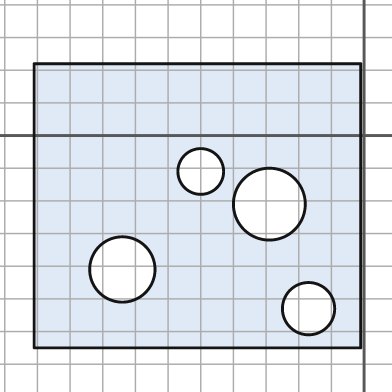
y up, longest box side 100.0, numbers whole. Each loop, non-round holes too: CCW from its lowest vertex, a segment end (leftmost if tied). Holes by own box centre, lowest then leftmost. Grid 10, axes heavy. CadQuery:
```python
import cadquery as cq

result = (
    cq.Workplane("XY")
    .moveTo(-101.0, -65.0)
    .lineTo(-1.0, -65.0)
    .lineTo(-1.0, 22.0)
    .lineTo(-101.0, 22.0)
    .close()
    .moveTo(-17.0, -53.0)
    .circle(8.0)
    .moveTo(-74.0, -41.0)
    .circle(10.0)
    .moveTo(-29.0, -21.0)
    .circle(11.0)
    .moveTo(-50.0, -11.0)
    .circle(7.0)
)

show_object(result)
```